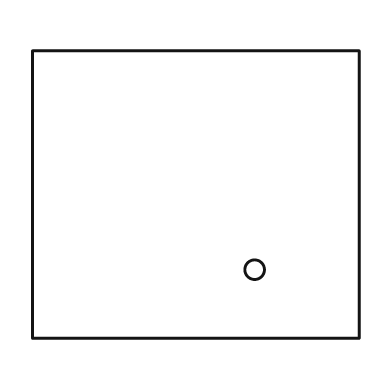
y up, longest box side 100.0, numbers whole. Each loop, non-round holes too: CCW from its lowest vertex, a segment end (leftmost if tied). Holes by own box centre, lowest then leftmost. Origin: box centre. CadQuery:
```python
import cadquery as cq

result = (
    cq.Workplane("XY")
    .moveTo(-50.0, -44.0)
    .lineTo(50.0, -44.0)
    .lineTo(50.0, 44.0)
    .lineTo(-50.0, 44.0)
    .close()
    .moveTo(18.0, -23.0)
    .circle(3.0)
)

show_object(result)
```